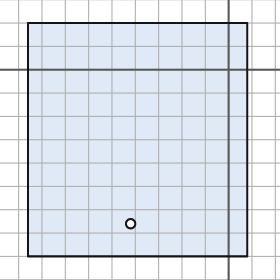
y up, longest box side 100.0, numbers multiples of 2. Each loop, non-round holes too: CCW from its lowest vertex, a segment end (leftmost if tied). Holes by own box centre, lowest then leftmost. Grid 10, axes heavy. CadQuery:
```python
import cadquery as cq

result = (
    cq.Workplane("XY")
    .moveTo(-86.0, -80.0)
    .lineTo(8.0, -80.0)
    .lineTo(8.0, 20.0)
    .lineTo(-86.0, 20.0)
    .close()
    .moveTo(-42.0, -66.0)
    .circle(2.0)
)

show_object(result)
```